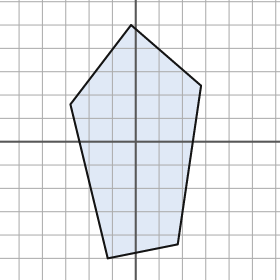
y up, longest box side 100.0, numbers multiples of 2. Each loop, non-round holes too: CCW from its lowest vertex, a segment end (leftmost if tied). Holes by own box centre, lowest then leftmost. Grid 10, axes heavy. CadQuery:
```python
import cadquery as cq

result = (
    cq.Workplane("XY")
    .moveTo(-12.0, -50.0)
    .lineTo(18.0, -44.0)
    .lineTo(28.0, 24.0)
    .lineTo(-2.0, 50.0)
    .lineTo(-28.0, 16.0)
    .close()
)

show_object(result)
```